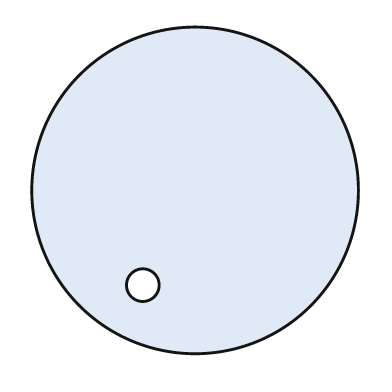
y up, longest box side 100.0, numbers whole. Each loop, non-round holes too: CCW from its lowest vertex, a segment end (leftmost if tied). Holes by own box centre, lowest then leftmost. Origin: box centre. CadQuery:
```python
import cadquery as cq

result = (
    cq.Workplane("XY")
    .moveTo(0.0, 0.0)
    .circle(50.0)
    .moveTo(-16.0, -29.0)
    .circle(5.0)
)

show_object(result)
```